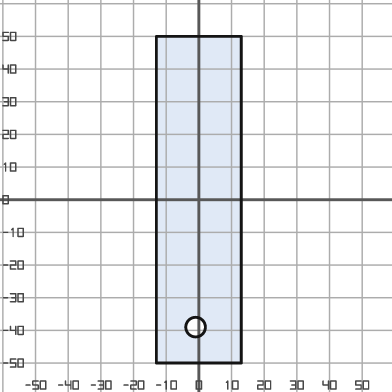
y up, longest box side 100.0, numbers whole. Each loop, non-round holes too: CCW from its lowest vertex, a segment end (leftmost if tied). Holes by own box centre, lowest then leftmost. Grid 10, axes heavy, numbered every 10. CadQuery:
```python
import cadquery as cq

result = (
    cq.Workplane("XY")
    .moveTo(-13.0, -50.0)
    .lineTo(13.0, -50.0)
    .lineTo(13.0, 50.0)
    .lineTo(-13.0, 50.0)
    .close()
    .moveTo(-1.0, -39.0)
    .circle(3.0)
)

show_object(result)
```